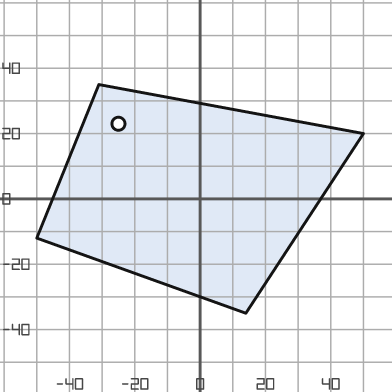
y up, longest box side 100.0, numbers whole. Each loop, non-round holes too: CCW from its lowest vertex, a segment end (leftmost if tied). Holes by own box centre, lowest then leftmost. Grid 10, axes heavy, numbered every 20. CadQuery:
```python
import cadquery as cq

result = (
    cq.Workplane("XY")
    .moveTo(14.0, -35.0)
    .lineTo(50.0, 20.0)
    .lineTo(-31.0, 35.0)
    .lineTo(-50.0, -12.0)
    .close()
    .moveTo(-25.0, 23.0)
    .circle(2.0)
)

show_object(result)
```